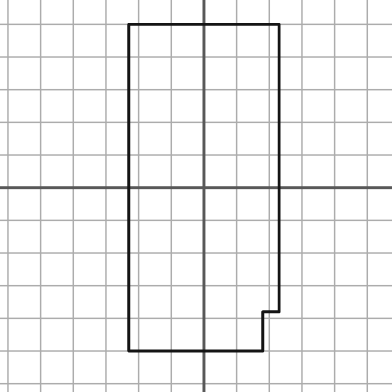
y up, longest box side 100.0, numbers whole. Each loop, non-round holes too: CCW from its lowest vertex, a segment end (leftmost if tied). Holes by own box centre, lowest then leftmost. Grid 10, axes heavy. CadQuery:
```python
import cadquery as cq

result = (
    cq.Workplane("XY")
    .moveTo(-23.0, -50.0)
    .lineTo(18.0, -50.0)
    .lineTo(18.0, -38.0)
    .lineTo(23.0, -38.0)
    .lineTo(23.0, 50.0)
    .lineTo(-23.0, 50.0)
    .close()
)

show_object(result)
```